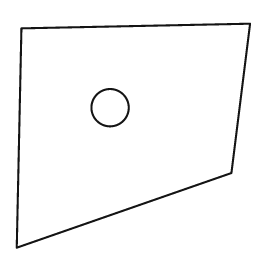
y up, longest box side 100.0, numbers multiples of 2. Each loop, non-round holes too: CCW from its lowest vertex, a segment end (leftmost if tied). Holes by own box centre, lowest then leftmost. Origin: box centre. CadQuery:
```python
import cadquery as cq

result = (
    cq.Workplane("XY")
    .moveTo(-50.0, -48.0)
    .lineTo(42.0, -16.0)
    .lineTo(50.0, 48.0)
    .lineTo(-48.0, 46.0)
    .close()
    .moveTo(-10.0, 12.0)
    .circle(8.0)
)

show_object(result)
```